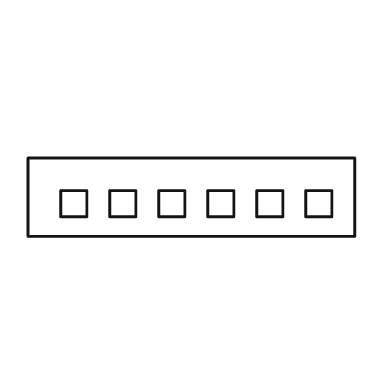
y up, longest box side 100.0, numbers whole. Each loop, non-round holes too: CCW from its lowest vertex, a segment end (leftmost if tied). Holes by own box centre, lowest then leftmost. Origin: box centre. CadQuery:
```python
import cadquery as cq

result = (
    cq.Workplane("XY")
    .moveTo(-50.0, -12.0)
    .lineTo(50.0, -12.0)
    .lineTo(50.0, 12.0)
    .lineTo(-50.0, 12.0)
    .close()
    .moveTo(-40.0, -6.0)
    .lineTo(-32.0, -6.0)
    .lineTo(-32.0, 2.0)
    .lineTo(-40.0, 2.0)
    .close()
    .moveTo(-25.0, -6.0)
    .lineTo(-17.0, -6.0)
    .lineTo(-17.0, 2.0)
    .lineTo(-25.0, 2.0)
    .close()
    .moveTo(-10.0, -6.0)
    .lineTo(-2.0, -6.0)
    .lineTo(-2.0, 2.0)
    .lineTo(-10.0, 2.0)
    .close()
    .moveTo(5.0, -6.0)
    .lineTo(13.0, -6.0)
    .lineTo(13.0, 2.0)
    .lineTo(5.0, 2.0)
    .close()
    .moveTo(20.0, -6.0)
    .lineTo(28.0, -6.0)
    .lineTo(28.0, 2.0)
    .lineTo(20.0, 2.0)
    .close()
    .moveTo(35.0, -6.0)
    .lineTo(43.0, -6.0)
    .lineTo(43.0, 2.0)
    .lineTo(35.0, 2.0)
    .close()
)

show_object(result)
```